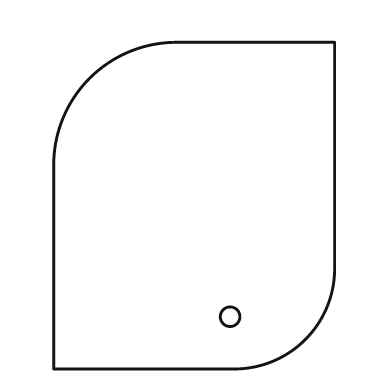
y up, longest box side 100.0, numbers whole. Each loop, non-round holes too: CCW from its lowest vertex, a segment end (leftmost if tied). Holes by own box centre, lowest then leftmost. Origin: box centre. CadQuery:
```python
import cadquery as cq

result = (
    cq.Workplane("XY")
    .moveTo(-43.0, -50.0)
    .lineTo(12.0, -50.0)
    .threePointArc((34.0, -41.0), (43.0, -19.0))
    .lineTo(43.0, 50.0)
    .lineTo(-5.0, 50.0)
    .threePointArc((-32.0, 39.0), (-43.0, 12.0))
    .close()
    .moveTo(11.0, -34.0)
    .circle(3.0)
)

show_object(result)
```